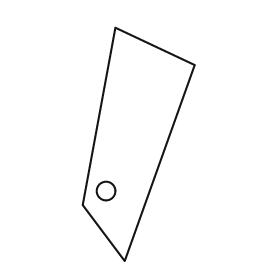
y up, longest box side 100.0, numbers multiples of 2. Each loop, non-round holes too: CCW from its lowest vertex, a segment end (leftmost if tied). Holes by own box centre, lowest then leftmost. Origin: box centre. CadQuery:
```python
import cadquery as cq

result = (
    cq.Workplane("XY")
    .moveTo(-6.0, -50.0)
    .lineTo(24.0, 34.0)
    .lineTo(-10.0, 50.0)
    .lineTo(-24.0, -26.0)
    .close()
    .moveTo(-14.0, -20.0)
    .circle(4.0)
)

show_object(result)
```